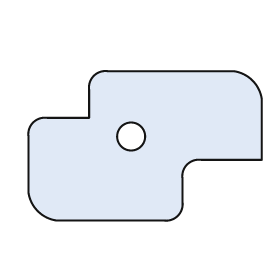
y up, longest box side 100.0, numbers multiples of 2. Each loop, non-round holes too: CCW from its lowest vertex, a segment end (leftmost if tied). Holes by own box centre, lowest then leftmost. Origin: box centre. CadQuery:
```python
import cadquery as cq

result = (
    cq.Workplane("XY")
    .moveTo(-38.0, -32.0)
    .lineTo(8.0, -32.0)
    .threePointArc((14.0, -30.0), (16.0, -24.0))
    .lineTo(16.0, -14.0)
    .threePointArc((18.0, -8.0), (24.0, -6.0))
    .lineTo(50.0, -6.0)
    .lineTo(50.0, 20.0)
    .threePointArc((46.0, 28.0), (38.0, 32.0))
    .lineTo(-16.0, 32.0)
    .threePointArc((-22.0, 30.0), (-24.0, 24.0))
    .lineTo(-24.0, 12.0)
    .lineTo(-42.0, 12.0)
    .threePointArc((-48.0, 10.0), (-50.0, 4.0))
    .lineTo(-50.0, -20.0)
    .threePointArc((-46.0, -28.0), (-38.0, -32.0))
    .close()
    .moveTo(-6.0, 4.0)
    .circle(6.0)
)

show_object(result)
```